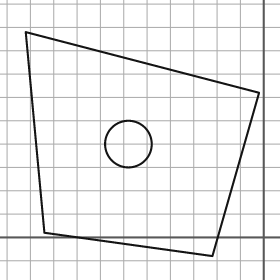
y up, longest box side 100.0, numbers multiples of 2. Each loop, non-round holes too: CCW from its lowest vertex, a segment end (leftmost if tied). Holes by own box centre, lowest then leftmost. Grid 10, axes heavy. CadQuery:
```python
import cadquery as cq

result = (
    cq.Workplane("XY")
    .moveTo(-22.0, -8.0)
    .lineTo(-2.0, 62.0)
    .lineTo(-102.0, 88.0)
    .lineTo(-94.0, 2.0)
    .close()
    .moveTo(-58.0, 40.0)
    .circle(10.0)
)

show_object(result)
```